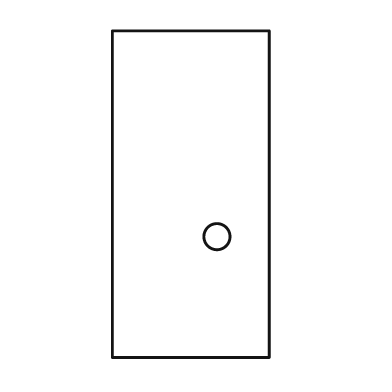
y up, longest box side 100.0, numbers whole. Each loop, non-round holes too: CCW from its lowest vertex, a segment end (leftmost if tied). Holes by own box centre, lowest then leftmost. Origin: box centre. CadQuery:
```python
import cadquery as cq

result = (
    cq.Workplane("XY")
    .moveTo(-24.0, -50.0)
    .lineTo(24.0, -50.0)
    .lineTo(24.0, 50.0)
    .lineTo(-24.0, 50.0)
    .close()
    .moveTo(8.0, -13.0)
    .circle(4.0)
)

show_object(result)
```